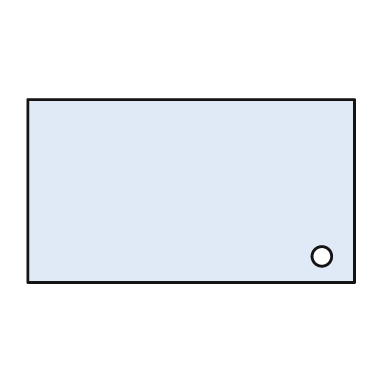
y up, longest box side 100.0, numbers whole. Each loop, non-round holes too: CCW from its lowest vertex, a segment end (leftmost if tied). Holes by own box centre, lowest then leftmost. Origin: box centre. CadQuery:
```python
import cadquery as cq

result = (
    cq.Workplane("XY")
    .moveTo(-50.0, -28.0)
    .lineTo(50.0, -28.0)
    .lineTo(50.0, 28.0)
    .lineTo(-50.0, 28.0)
    .close()
    .moveTo(40.0, -20.0)
    .circle(3.0)
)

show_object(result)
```